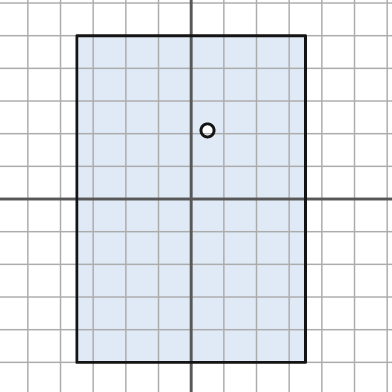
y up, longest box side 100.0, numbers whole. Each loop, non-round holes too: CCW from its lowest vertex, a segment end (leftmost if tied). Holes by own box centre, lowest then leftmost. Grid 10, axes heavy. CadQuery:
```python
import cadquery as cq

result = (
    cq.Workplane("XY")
    .moveTo(-35.0, -50.0)
    .lineTo(35.0, -50.0)
    .lineTo(35.0, 50.0)
    .lineTo(-35.0, 50.0)
    .close()
    .moveTo(5.0, 21.0)
    .circle(2.0)
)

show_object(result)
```